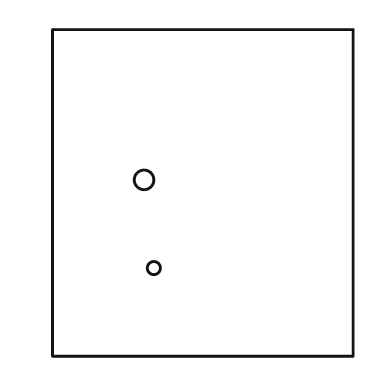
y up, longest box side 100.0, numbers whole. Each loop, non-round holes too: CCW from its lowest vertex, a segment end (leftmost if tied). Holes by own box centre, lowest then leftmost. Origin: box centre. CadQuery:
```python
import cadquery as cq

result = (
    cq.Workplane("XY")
    .moveTo(-46.0, -50.0)
    .lineTo(46.0, -50.0)
    .lineTo(46.0, 50.0)
    .lineTo(-46.0, 50.0)
    .close()
    .moveTo(-15.0, -23.0)
    .circle(2.0)
    .moveTo(-18.0, 4.0)
    .circle(3.0)
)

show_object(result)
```